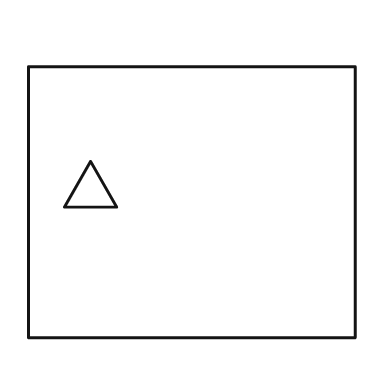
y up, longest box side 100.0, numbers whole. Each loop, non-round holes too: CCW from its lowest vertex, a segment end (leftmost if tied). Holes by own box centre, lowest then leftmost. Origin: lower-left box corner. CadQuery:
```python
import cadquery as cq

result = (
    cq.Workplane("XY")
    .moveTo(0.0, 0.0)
    .lineTo(100.0, 0.0)
    .lineTo(100.0, 83.0)
    .lineTo(0.0, 83.0)
    .close()
    .moveTo(11.0, 40.0)
    .lineTo(27.0, 40.0)
    .lineTo(19.0, 54.0)
    .close()
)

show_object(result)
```